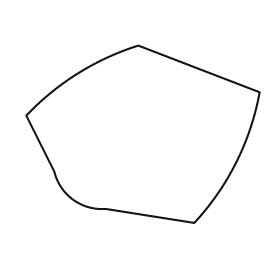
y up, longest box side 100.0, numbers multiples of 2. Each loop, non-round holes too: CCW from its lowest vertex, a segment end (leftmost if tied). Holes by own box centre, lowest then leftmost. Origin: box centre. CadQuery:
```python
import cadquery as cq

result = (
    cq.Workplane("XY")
    .moveTo(22.0, -38.0)
    .threePointArc((40.0, -12.0), (50.0, 18.0))
    .lineTo(-2.0, 38.0)
    .threePointArc((-28.0, 26.0), (-50.0, 8.0))
    .lineTo(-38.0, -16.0)
    .threePointArc((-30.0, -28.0), (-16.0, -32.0))
    .close()
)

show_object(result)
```